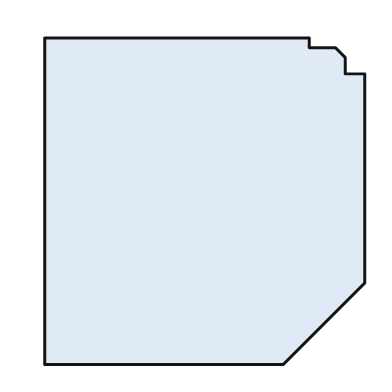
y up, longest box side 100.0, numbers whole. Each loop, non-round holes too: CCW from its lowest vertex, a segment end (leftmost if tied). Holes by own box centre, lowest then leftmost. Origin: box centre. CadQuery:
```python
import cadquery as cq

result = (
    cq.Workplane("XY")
    .moveTo(-49.0, -50.0)
    .lineTo(24.0, -50.0)
    .lineTo(49.0, -25.0)
    .lineTo(49.0, 39.0)
    .lineTo(43.0, 39.0)
    .lineTo(43.0, 44.0)
    .lineTo(40.0, 47.0)
    .lineTo(32.0, 47.0)
    .lineTo(32.0, 50.0)
    .lineTo(-49.0, 50.0)
    .close()
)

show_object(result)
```